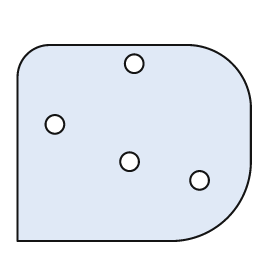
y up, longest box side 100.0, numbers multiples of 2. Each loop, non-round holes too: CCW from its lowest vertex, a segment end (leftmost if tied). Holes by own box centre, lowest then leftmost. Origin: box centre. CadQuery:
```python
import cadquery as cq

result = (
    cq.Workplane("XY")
    .moveTo(-50.0, -42.0)
    .lineTo(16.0, -42.0)
    .threePointArc((40.0, -32.0), (50.0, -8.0))
    .lineTo(50.0, 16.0)
    .threePointArc((42.0, 34.0), (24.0, 42.0))
    .lineTo(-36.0, 42.0)
    .threePointArc((-46.0, 38.0), (-50.0, 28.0))
    .close()
    .moveTo(28.0, -16.0)
    .circle(4.0)
    .moveTo(-2.0, -8.0)
    .circle(4.0)
    .moveTo(-34.0, 8.0)
    .circle(4.0)
    .moveTo(0.0, 34.0)
    .circle(4.0)
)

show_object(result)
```